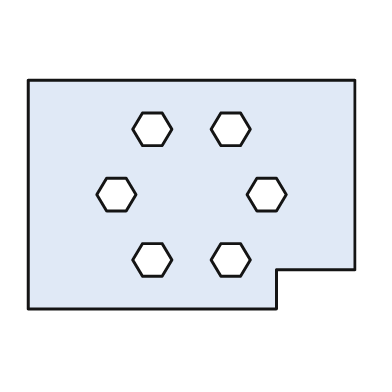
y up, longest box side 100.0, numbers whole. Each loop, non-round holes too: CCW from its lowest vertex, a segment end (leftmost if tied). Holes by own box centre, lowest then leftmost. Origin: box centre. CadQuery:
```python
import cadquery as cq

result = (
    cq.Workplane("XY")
    .moveTo(-50.0, -35.0)
    .lineTo(26.0, -35.0)
    .lineTo(26.0, -23.0)
    .lineTo(50.0, -23.0)
    .lineTo(50.0, 35.0)
    .lineTo(-50.0, 35.0)
    .close()
    .moveTo(-15.0, -25.0)
    .lineTo(-9.0, -25.0)
    .lineTo(-6.0, -20.0)
    .lineTo(-9.0, -15.0)
    .lineTo(-15.0, -15.0)
    .lineTo(-18.0, -20.0)
    .close()
    .moveTo(9.0, -25.0)
    .lineTo(15.0, -25.0)
    .lineTo(18.0, -20.0)
    .lineTo(15.0, -15.0)
    .lineTo(9.0, -15.0)
    .lineTo(6.0, -20.0)
    .close()
    .moveTo(-26.0, -5.0)
    .lineTo(-20.0, -5.0)
    .lineTo(-17.0, 0.0)
    .lineTo(-20.0, 5.0)
    .lineTo(-26.0, 5.0)
    .lineTo(-29.0, 0.0)
    .close()
    .moveTo(20.0, -5.0)
    .lineTo(26.0, -5.0)
    .lineTo(29.0, 0.0)
    .lineTo(26.0, 5.0)
    .lineTo(20.0, 5.0)
    .lineTo(17.0, 0.0)
    .close()
    .moveTo(-15.0, 15.0)
    .lineTo(-9.0, 15.0)
    .lineTo(-6.0, 20.0)
    .lineTo(-9.0, 25.0)
    .lineTo(-15.0, 25.0)
    .lineTo(-18.0, 20.0)
    .close()
    .moveTo(9.0, 15.0)
    .lineTo(15.0, 15.0)
    .lineTo(18.0, 20.0)
    .lineTo(15.0, 25.0)
    .lineTo(9.0, 25.0)
    .lineTo(6.0, 20.0)
    .close()
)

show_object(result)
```